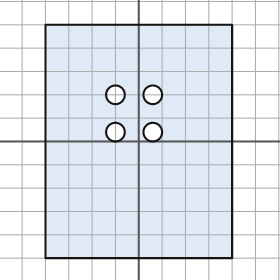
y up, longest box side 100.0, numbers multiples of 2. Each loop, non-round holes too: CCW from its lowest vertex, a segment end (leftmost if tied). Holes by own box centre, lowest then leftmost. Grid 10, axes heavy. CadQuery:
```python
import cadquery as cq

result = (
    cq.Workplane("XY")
    .moveTo(-40.0, -50.0)
    .lineTo(40.0, -50.0)
    .lineTo(40.0, 50.0)
    .lineTo(-40.0, 50.0)
    .close()
    .moveTo(-10.0, 4.0)
    .circle(4.0)
    .moveTo(6.0, 4.0)
    .circle(4.0)
    .moveTo(-10.0, 20.0)
    .circle(4.0)
    .moveTo(6.0, 20.0)
    .circle(4.0)
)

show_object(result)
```